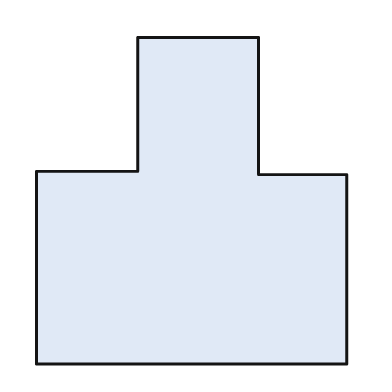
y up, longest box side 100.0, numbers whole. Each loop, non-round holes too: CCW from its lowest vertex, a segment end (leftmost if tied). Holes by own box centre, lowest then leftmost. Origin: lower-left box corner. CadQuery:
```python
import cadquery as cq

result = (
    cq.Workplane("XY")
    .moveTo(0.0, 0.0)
    .lineTo(95.0, 0.0)
    .lineTo(95.0, 58.0)
    .lineTo(68.0, 58.0)
    .lineTo(68.0, 100.0)
    .lineTo(31.0, 100.0)
    .lineTo(31.0, 59.0)
    .lineTo(0.0, 59.0)
    .close()
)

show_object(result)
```